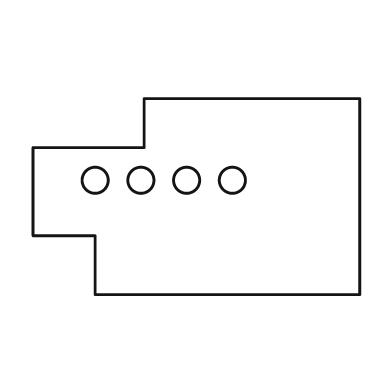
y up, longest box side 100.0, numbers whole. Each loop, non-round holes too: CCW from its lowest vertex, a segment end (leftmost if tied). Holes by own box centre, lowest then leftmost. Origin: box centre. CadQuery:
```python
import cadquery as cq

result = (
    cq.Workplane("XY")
    .moveTo(-31.0, -30.0)
    .lineTo(50.0, -30.0)
    .lineTo(50.0, 30.0)
    .lineTo(-16.0, 30.0)
    .lineTo(-16.0, 15.0)
    .lineTo(-50.0, 15.0)
    .lineTo(-50.0, -12.0)
    .lineTo(-31.0, -12.0)
    .close()
    .moveTo(-31.0, 5.0)
    .circle(4.0)
    .moveTo(-17.0, 5.0)
    .circle(4.0)
    .moveTo(-3.0, 5.0)
    .circle(4.0)
    .moveTo(11.0, 5.0)
    .circle(4.0)
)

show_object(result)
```